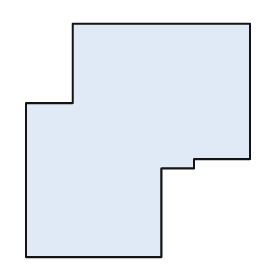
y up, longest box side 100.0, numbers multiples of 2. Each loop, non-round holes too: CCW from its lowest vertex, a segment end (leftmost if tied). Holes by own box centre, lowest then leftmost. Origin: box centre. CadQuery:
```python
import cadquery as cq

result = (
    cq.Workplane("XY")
    .moveTo(-48.0, -50.0)
    .lineTo(10.0, -50.0)
    .lineTo(10.0, -12.0)
    .lineTo(24.0, -12.0)
    .lineTo(24.0, -8.0)
    .lineTo(48.0, -8.0)
    .lineTo(48.0, 50.0)
    .lineTo(-28.0, 50.0)
    .lineTo(-28.0, 16.0)
    .lineTo(-48.0, 16.0)
    .close()
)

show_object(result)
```